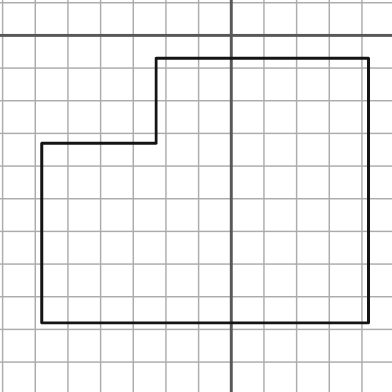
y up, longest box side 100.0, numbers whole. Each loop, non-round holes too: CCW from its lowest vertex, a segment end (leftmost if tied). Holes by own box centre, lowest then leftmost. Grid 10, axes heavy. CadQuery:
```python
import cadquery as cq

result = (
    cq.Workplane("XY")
    .moveTo(-58.0, -88.0)
    .lineTo(42.0, -88.0)
    .lineTo(42.0, -7.0)
    .lineTo(-23.0, -7.0)
    .lineTo(-23.0, -33.0)
    .lineTo(-58.0, -33.0)
    .close()
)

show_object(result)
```